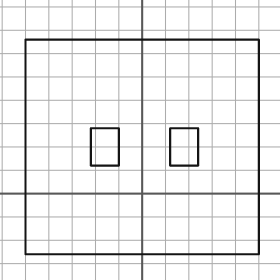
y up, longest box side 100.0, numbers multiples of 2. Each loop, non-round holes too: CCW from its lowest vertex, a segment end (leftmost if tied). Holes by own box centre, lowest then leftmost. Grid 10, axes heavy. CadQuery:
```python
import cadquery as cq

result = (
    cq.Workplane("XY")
    .moveTo(-50.0, -26.0)
    .lineTo(50.0, -26.0)
    .lineTo(50.0, 66.0)
    .lineTo(-50.0, 66.0)
    .close()
    .moveTo(-22.0, 12.0)
    .lineTo(-10.0, 12.0)
    .lineTo(-10.0, 28.0)
    .lineTo(-22.0, 28.0)
    .close()
    .moveTo(12.0, 12.0)
    .lineTo(24.0, 12.0)
    .lineTo(24.0, 28.0)
    .lineTo(12.0, 28.0)
    .close()
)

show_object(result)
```